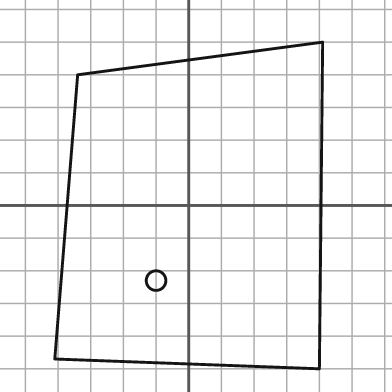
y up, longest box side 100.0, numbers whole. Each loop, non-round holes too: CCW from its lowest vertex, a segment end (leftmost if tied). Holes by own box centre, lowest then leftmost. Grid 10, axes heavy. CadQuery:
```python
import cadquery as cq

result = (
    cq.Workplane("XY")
    .moveTo(40.0, -50.0)
    .lineTo(41.0, 50.0)
    .lineTo(-34.0, 40.0)
    .lineTo(-41.0, -47.0)
    .close()
    .moveTo(-10.0, -23.0)
    .circle(3.0)
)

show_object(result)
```